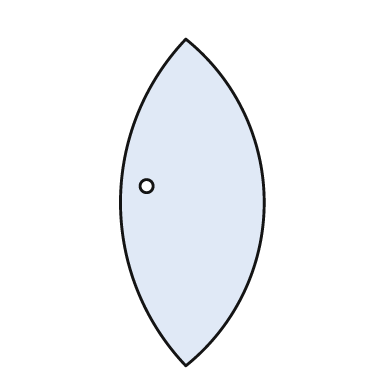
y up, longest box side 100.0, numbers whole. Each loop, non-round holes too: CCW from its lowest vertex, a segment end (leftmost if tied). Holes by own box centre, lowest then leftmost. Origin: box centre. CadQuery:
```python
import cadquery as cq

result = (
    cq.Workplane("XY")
    .moveTo(-2.0, -50.0)
    .threePointArc((22.0, 0.0), (-2.0, 50.0))
    .threePointArc((-22.0, 0.0), (-2.0, -50.0))
    .close()
    .moveTo(-14.0, 5.0)
    .circle(2.0)
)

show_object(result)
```